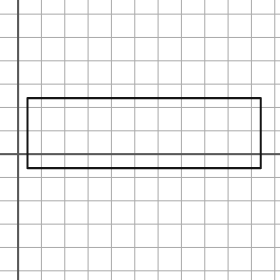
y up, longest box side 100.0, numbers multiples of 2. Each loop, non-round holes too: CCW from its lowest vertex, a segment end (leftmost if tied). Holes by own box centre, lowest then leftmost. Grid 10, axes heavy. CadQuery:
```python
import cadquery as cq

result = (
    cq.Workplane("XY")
    .moveTo(4.0, -6.0)
    .lineTo(104.0, -6.0)
    .lineTo(104.0, 24.0)
    .lineTo(4.0, 24.0)
    .close()
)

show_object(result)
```